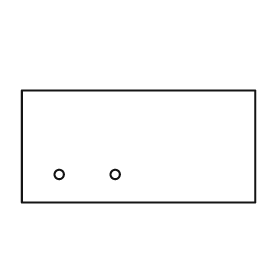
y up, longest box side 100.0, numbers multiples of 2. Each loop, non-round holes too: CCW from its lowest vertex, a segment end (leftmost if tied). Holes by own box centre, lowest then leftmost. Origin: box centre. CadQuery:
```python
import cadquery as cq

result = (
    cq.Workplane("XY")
    .moveTo(-50.0, -24.0)
    .lineTo(50.0, -24.0)
    .lineTo(50.0, 24.0)
    .lineTo(-50.0, 24.0)
    .close()
    .moveTo(-34.0, -12.0)
    .circle(2.0)
    .moveTo(-10.0, -12.0)
    .circle(2.0)
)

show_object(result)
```